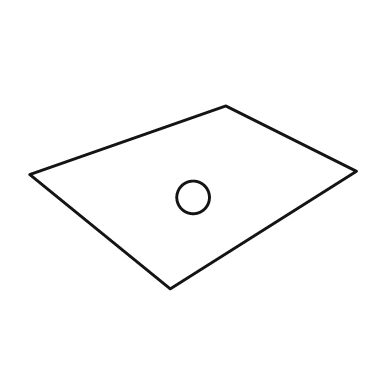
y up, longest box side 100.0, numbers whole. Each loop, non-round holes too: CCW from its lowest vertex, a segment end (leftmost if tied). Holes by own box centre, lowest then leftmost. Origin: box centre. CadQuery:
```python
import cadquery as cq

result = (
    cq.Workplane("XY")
    .moveTo(-7.0, -28.0)
    .lineTo(50.0, 8.0)
    .lineTo(10.0, 28.0)
    .lineTo(-50.0, 7.0)
    .close()
    .moveTo(0.0, 0.0)
    .circle(5.0)
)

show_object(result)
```